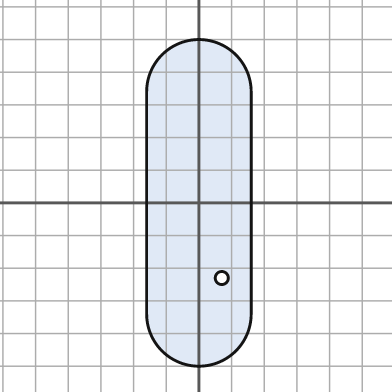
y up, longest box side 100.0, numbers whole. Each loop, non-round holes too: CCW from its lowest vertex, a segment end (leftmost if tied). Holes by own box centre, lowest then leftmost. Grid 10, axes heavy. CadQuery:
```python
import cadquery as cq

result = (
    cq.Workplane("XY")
    .moveTo(-16.0, -34.0)
    .threePointArc((0.0, -50.0), (16.0, -34.0))
    .lineTo(16.0, 34.0)
    .threePointArc((0.0, 50.0), (-16.0, 34.0))
    .close()
    .moveTo(7.0, -23.0)
    .circle(2.0)
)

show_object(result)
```